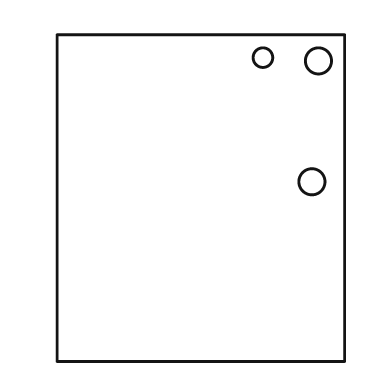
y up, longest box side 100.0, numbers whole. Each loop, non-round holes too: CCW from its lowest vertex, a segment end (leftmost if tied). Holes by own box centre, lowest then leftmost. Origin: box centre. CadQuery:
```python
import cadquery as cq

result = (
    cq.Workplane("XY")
    .moveTo(-44.0, -50.0)
    .lineTo(44.0, -50.0)
    .lineTo(44.0, 50.0)
    .lineTo(-44.0, 50.0)
    .close()
    .moveTo(34.0, 5.0)
    .circle(4.0)
    .moveTo(36.0, 42.0)
    .circle(4.0)
    .moveTo(19.0, 43.0)
    .circle(3.0)
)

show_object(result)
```